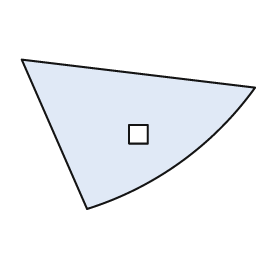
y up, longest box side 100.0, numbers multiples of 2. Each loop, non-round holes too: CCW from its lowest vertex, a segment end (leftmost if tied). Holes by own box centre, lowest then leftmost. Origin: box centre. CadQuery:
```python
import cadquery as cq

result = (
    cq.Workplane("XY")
    .moveTo(-22.0, -32.0)
    .threePointArc((18.0, -12.0), (50.0, 20.0))
    .lineTo(-50.0, 32.0)
    .close()
    .moveTo(-4.0, -4.0)
    .lineTo(4.0, -4.0)
    .lineTo(4.0, 4.0)
    .lineTo(-4.0, 4.0)
    .close()
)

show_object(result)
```